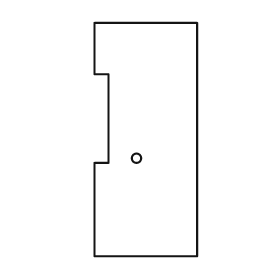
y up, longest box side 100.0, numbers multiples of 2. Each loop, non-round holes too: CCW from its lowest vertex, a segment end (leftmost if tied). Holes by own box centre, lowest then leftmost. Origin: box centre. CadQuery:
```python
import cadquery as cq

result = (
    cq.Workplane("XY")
    .moveTo(-22.0, -50.0)
    .lineTo(22.0, -50.0)
    .lineTo(22.0, 50.0)
    .lineTo(-22.0, 50.0)
    .lineTo(-22.0, 28.0)
    .lineTo(-16.0, 28.0)
    .lineTo(-16.0, -10.0)
    .lineTo(-22.0, -10.0)
    .close()
    .moveTo(-4.0, -8.0)
    .circle(2.0)
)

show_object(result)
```